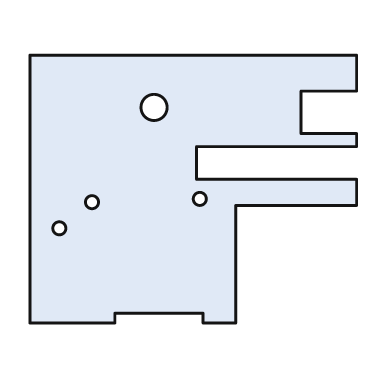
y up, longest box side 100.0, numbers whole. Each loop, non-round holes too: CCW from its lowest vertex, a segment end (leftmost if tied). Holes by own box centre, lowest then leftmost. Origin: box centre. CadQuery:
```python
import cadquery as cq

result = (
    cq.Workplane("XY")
    .moveTo(-50.0, -41.0)
    .lineTo(-24.0, -41.0)
    .lineTo(-24.0, -38.0)
    .lineTo(3.0, -38.0)
    .lineTo(3.0, -41.0)
    .lineTo(13.0, -41.0)
    .lineTo(13.0, -5.0)
    .lineTo(50.0, -5.0)
    .lineTo(50.0, 3.0)
    .lineTo(1.0, 3.0)
    .lineTo(1.0, 13.0)
    .lineTo(50.0, 13.0)
    .lineTo(50.0, 17.0)
    .lineTo(33.0, 17.0)
    .lineTo(33.0, 30.0)
    .lineTo(50.0, 30.0)
    .lineTo(50.0, 41.0)
    .lineTo(-50.0, 41.0)
    .close()
    .moveTo(-41.0, -12.0)
    .circle(2.0)
    .moveTo(-31.0, -4.0)
    .circle(2.0)
    .moveTo(2.0, -3.0)
    .circle(2.0)
    .moveTo(-12.0, 25.0)
    .circle(4.0)
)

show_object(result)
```